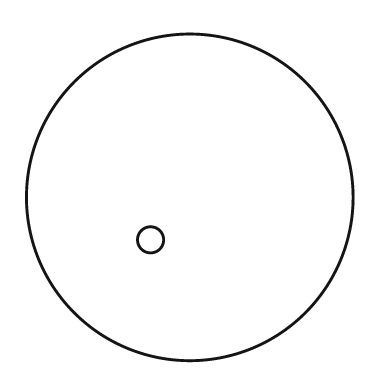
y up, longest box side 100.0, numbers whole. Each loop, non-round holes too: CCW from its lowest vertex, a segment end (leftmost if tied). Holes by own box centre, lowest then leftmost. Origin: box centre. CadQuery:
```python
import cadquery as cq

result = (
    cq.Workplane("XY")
    .moveTo(0.0, 0.0)
    .circle(50.0)
    .moveTo(-12.0, -13.0)
    .circle(4.0)
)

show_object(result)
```